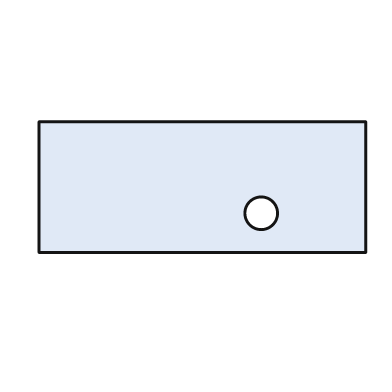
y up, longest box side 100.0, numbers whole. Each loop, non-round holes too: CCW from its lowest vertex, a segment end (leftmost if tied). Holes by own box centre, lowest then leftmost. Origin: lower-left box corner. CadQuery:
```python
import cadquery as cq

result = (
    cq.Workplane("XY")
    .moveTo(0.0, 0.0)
    .lineTo(100.0, 0.0)
    .lineTo(100.0, 40.0)
    .lineTo(0.0, 40.0)
    .close()
    .moveTo(68.0, 12.0)
    .circle(5.0)
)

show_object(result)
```